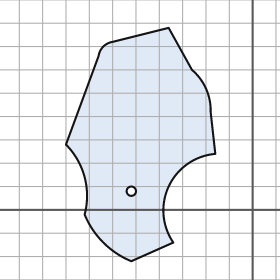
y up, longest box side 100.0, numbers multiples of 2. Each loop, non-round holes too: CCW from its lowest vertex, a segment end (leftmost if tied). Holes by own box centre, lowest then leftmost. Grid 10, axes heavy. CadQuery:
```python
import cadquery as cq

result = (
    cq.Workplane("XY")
    .moveTo(-52.0, -22.0)
    .lineTo(-34.0, -14.0)
    .threePointArc((-36.0, 10.0), (-16.0, 24.0))
    .lineTo(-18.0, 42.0)
    .threePointArc((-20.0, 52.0), (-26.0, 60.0))
    .lineTo(-36.0, 78.0)
    .lineTo(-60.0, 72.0)
    .threePointArc((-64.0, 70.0), (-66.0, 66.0))
    .lineTo(-80.0, 28.0)
    .threePointArc((-72.0, 14.0), (-72.0, -2.0))
    .threePointArc((-64.0, -14.0), (-52.0, -22.0))
    .close()
    .moveTo(-52.0, 8.0)
    .circle(2.0)
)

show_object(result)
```